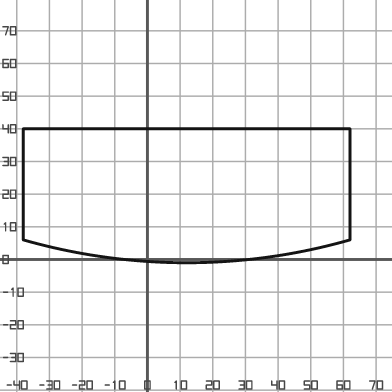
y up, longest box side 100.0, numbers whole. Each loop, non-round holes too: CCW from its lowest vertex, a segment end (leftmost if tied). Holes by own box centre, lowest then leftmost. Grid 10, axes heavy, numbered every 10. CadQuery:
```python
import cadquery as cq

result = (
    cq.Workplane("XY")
    .moveTo(-38.0, 6.0)
    .threePointArc((12.0, -1.0), (62.0, 6.0))
    .lineTo(62.0, 40.0)
    .lineTo(-38.0, 40.0)
    .close()
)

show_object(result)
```